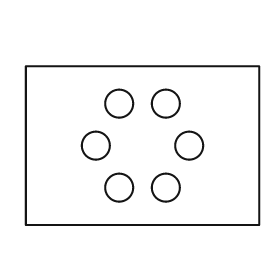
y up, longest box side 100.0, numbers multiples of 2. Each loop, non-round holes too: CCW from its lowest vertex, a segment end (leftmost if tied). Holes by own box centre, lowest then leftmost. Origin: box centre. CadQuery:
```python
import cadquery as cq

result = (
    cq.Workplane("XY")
    .moveTo(-50.0, -34.0)
    .lineTo(50.0, -34.0)
    .lineTo(50.0, 34.0)
    .lineTo(-50.0, 34.0)
    .close()
    .moveTo(-10.0, -18.0)
    .circle(6.0)
    .moveTo(10.0, -18.0)
    .circle(6.0)
    .moveTo(-20.0, 0.0)
    .circle(6.0)
    .moveTo(20.0, 0.0)
    .circle(6.0)
    .moveTo(-10.0, 18.0)
    .circle(6.0)
    .moveTo(10.0, 18.0)
    .circle(6.0)
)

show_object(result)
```